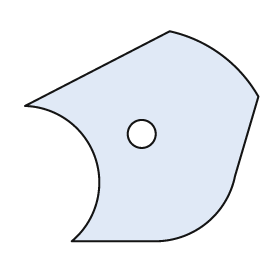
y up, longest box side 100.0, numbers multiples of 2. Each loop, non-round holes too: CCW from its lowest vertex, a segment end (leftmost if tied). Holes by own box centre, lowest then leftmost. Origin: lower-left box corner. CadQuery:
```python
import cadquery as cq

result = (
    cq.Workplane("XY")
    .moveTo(20.0, 0.0)
    .lineTo(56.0, 0.0)
    .threePointArc((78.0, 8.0), (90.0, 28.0))
    .lineTo(100.0, 62.0)
    .threePointArc((84.0, 80.0), (62.0, 90.0))
    .lineTo(0.0, 58.0)
    .threePointArc((30.0, 36.0), (20.0, 0.0))
    .close()
    .moveTo(50.0, 46.0)
    .circle(6.0)
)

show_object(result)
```